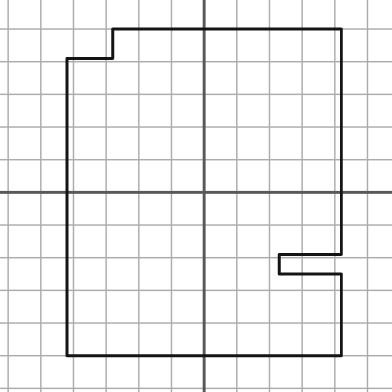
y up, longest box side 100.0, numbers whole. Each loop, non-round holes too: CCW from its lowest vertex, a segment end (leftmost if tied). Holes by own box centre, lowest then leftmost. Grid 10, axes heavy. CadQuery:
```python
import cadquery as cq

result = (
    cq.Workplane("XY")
    .moveTo(-42.0, -50.0)
    .lineTo(42.0, -50.0)
    .lineTo(42.0, -25.0)
    .lineTo(23.0, -25.0)
    .lineTo(23.0, -19.0)
    .lineTo(42.0, -19.0)
    .lineTo(42.0, 50.0)
    .lineTo(-28.0, 50.0)
    .lineTo(-28.0, 41.0)
    .lineTo(-42.0, 41.0)
    .close()
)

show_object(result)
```